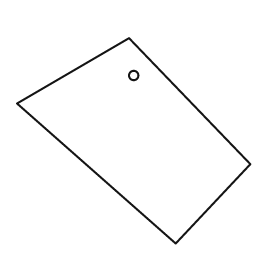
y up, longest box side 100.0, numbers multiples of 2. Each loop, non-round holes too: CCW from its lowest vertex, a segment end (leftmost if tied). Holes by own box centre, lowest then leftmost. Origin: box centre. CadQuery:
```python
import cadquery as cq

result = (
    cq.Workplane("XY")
    .moveTo(18.0, -44.0)
    .lineTo(50.0, -10.0)
    .lineTo(-2.0, 44.0)
    .lineTo(-50.0, 16.0)
    .close()
    .moveTo(0.0, 28.0)
    .circle(2.0)
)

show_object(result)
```